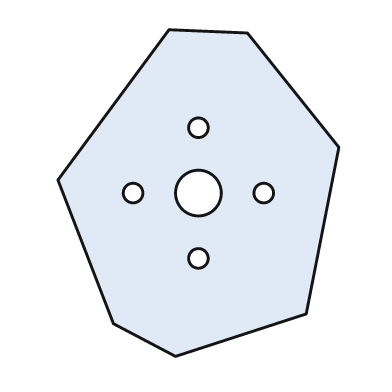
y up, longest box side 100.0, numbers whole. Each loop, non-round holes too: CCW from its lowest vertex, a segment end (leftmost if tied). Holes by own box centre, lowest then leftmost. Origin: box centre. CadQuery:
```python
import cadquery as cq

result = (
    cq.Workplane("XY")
    .moveTo(-7.0, -50.0)
    .lineTo(33.0, -37.0)
    .lineTo(43.0, 14.0)
    .lineTo(15.0, 49.0)
    .lineTo(-9.0, 50.0)
    .lineTo(-43.0, 4.0)
    .lineTo(-26.0, -40.0)
    .close()
    .moveTo(0.0, -20.0)
    .circle(3.0)
    .moveTo(-20.0, 0.0)
    .circle(3.0)
    .moveTo(0.0, 0.0)
    .circle(7.0)
    .moveTo(20.0, 0.0)
    .circle(3.0)
    .moveTo(0.0, 20.0)
    .circle(3.0)
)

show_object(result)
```